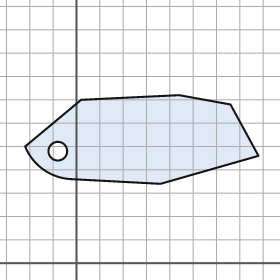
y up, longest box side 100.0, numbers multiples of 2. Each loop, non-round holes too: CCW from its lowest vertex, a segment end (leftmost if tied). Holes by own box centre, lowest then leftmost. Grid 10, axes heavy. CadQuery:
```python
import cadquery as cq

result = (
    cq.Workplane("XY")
    .moveTo(36.0, 34.0)
    .lineTo(78.0, 46.0)
    .lineTo(66.0, 68.0)
    .lineTo(44.0, 72.0)
    .lineTo(2.0, 70.0)
    .lineTo(-22.0, 50.0)
    .threePointArc((-14.0, 40.0), (-2.0, 36.0))
    .close()
    .moveTo(-8.0, 48.0)
    .circle(4.0)
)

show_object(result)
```